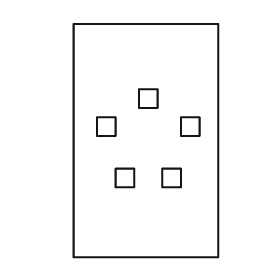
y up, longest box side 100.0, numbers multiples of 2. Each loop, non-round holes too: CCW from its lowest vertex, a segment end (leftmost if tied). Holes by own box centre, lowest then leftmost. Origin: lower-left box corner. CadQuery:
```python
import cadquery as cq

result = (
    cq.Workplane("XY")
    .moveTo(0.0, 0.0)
    .lineTo(62.0, 0.0)
    .lineTo(62.0, 100.0)
    .lineTo(0.0, 100.0)
    .close()
    .moveTo(18.0, 30.0)
    .lineTo(26.0, 30.0)
    .lineTo(26.0, 38.0)
    .lineTo(18.0, 38.0)
    .close()
    .moveTo(38.0, 30.0)
    .lineTo(46.0, 30.0)
    .lineTo(46.0, 38.0)
    .lineTo(38.0, 38.0)
    .close()
    .moveTo(10.0, 52.0)
    .lineTo(18.0, 52.0)
    .lineTo(18.0, 60.0)
    .lineTo(10.0, 60.0)
    .close()
    .moveTo(46.0, 52.0)
    .lineTo(54.0, 52.0)
    .lineTo(54.0, 60.0)
    .lineTo(46.0, 60.0)
    .close()
    .moveTo(28.0, 64.0)
    .lineTo(36.0, 64.0)
    .lineTo(36.0, 72.0)
    .lineTo(28.0, 72.0)
    .close()
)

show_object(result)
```